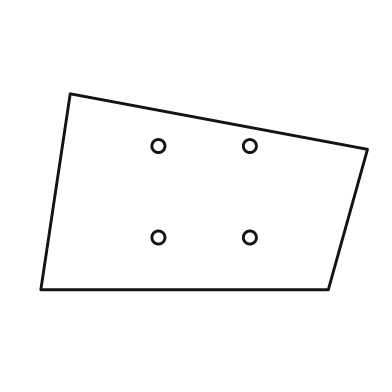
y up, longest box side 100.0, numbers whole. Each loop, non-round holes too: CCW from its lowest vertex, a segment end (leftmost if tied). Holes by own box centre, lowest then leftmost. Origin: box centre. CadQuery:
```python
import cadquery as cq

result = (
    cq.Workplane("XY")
    .moveTo(-50.0, -30.0)
    .lineTo(38.0, -30.0)
    .lineTo(50.0, 13.0)
    .lineTo(-41.0, 30.0)
    .close()
    .moveTo(-14.0, -14.0)
    .circle(2.0)
    .moveTo(14.0, -14.0)
    .circle(2.0)
    .moveTo(-14.0, 14.0)
    .circle(2.0)
    .moveTo(14.0, 14.0)
    .circle(2.0)
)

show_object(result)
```